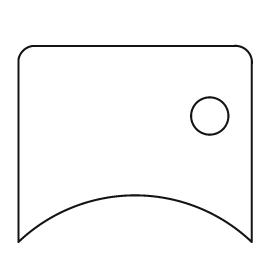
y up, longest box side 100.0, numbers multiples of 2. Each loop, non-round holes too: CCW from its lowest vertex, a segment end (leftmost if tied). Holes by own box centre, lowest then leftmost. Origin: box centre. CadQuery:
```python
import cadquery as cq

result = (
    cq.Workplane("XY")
    .moveTo(-50.0, -42.0)
    .threePointArc((0.0, -22.0), (50.0, -42.0))
    .lineTo(50.0, 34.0)
    .threePointArc((48.0, 40.0), (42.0, 42.0))
    .lineTo(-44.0, 42.0)
    .threePointArc((-48.0, 40.0), (-50.0, 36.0))
    .close()
    .moveTo(32.0, 12.0)
    .circle(8.0)
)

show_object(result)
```